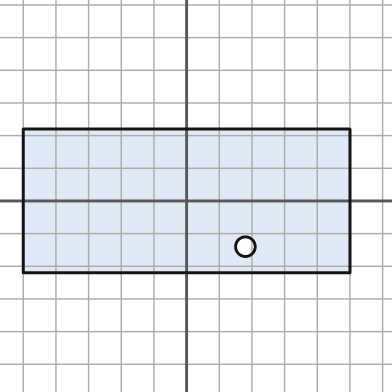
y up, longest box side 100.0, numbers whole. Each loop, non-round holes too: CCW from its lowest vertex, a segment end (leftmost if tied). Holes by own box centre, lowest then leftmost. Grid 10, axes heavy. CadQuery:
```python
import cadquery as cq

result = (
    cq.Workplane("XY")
    .moveTo(-50.0, -22.0)
    .lineTo(50.0, -22.0)
    .lineTo(50.0, 22.0)
    .lineTo(-50.0, 22.0)
    .close()
    .moveTo(18.0, -14.0)
    .circle(3.0)
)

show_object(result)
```